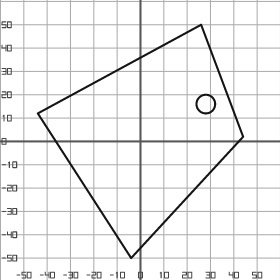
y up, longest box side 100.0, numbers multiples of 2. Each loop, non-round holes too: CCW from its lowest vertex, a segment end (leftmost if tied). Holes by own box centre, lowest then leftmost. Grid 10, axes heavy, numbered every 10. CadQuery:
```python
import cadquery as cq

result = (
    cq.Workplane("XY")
    .moveTo(-4.0, -50.0)
    .lineTo(44.0, 2.0)
    .lineTo(26.0, 50.0)
    .lineTo(-44.0, 12.0)
    .close()
    .moveTo(28.0, 16.0)
    .circle(4.0)
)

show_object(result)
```